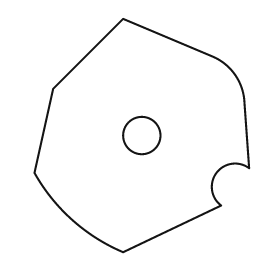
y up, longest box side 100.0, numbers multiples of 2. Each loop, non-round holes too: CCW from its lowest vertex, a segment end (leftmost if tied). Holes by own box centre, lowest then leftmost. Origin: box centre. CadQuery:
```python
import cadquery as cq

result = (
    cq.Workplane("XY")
    .moveTo(-8.0, -50.0)
    .lineTo(34.0, -30.0)
    .threePointArc((32.0, -16.0), (46.0, -14.0))
    .lineTo(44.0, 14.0)
    .threePointArc((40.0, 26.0), (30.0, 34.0))
    .lineTo(-8.0, 50.0)
    .lineTo(-38.0, 20.0)
    .lineTo(-46.0, -16.0)
    .threePointArc((-30.0, -36.0), (-8.0, -50.0))
    .close()
    .moveTo(0.0, 0.0)
    .circle(8.0)
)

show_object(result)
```